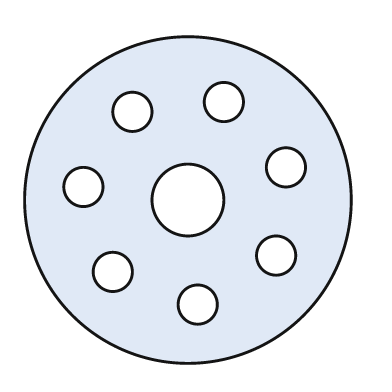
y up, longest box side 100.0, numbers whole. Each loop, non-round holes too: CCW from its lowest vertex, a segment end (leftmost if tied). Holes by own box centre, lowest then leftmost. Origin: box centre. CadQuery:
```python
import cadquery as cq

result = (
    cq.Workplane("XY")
    .moveTo(0.0, 0.0)
    .circle(50.0)
    .moveTo(3.0, -32.0)
    .circle(6.0)
    .moveTo(-23.0, -22.0)
    .circle(6.0)
    .moveTo(27.0, -17.0)
    .circle(6.0)
    .moveTo(0.0, 0.0)
    .circle(11.0)
    .moveTo(-32.0, 4.0)
    .circle(6.0)
    .moveTo(30.0, 10.0)
    .circle(6.0)
    .moveTo(-17.0, 27.0)
    .circle(6.0)
    .moveTo(11.0, 30.0)
    .circle(6.0)
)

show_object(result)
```